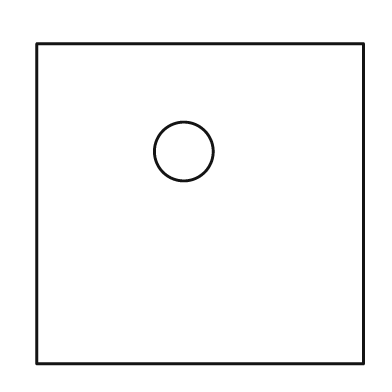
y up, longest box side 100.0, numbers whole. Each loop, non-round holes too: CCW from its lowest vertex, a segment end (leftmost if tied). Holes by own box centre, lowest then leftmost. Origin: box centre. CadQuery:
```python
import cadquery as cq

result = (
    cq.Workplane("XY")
    .moveTo(-50.0, -49.0)
    .lineTo(50.0, -49.0)
    .lineTo(50.0, 49.0)
    .lineTo(-50.0, 49.0)
    .close()
    .moveTo(-5.0, 16.0)
    .circle(9.0)
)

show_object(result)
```